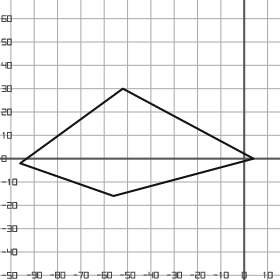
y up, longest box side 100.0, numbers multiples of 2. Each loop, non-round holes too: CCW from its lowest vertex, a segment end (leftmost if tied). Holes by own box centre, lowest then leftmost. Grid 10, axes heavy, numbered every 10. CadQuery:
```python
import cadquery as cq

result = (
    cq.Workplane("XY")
    .moveTo(-56.0, -16.0)
    .lineTo(4.0, 0.0)
    .lineTo(-52.0, 30.0)
    .lineTo(-96.0, -2.0)
    .close()
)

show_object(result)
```